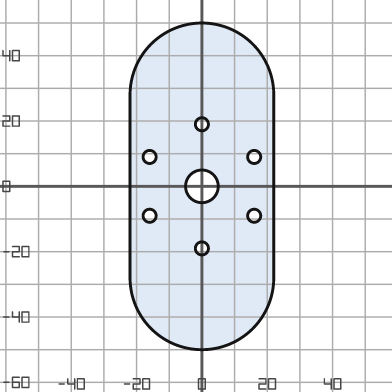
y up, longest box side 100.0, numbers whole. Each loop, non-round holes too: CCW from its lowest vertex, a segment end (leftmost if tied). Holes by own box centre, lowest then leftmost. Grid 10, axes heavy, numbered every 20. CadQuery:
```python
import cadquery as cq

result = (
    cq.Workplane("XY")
    .moveTo(-22.0, -28.0)
    .threePointArc((0.0, -50.0), (22.0, -28.0))
    .lineTo(22.0, 28.0)
    .threePointArc((0.0, 50.0), (-22.0, 28.0))
    .close()
    .moveTo(0.0, -19.0)
    .circle(2.0)
    .moveTo(-16.0, -9.0)
    .circle(2.0)
    .moveTo(16.0, -9.0)
    .circle(2.0)
    .moveTo(0.0, 0.0)
    .circle(5.0)
    .moveTo(-16.0, 9.0)
    .circle(2.0)
    .moveTo(16.0, 9.0)
    .circle(2.0)
    .moveTo(0.0, 19.0)
    .circle(2.0)
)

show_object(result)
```